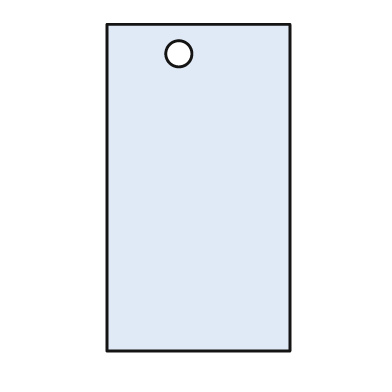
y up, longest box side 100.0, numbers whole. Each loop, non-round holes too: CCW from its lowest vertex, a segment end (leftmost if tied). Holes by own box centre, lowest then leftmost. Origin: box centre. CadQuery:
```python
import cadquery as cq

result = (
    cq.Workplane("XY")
    .moveTo(-28.0, -50.0)
    .lineTo(28.0, -50.0)
    .lineTo(28.0, 50.0)
    .lineTo(-28.0, 50.0)
    .close()
    .moveTo(-6.0, 41.0)
    .circle(4.0)
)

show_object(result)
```